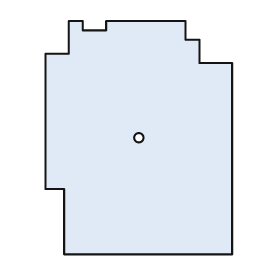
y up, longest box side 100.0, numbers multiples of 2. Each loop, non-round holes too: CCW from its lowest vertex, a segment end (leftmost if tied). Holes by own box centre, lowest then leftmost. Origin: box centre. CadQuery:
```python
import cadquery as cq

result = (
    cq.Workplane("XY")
    .moveTo(-32.0, -50.0)
    .lineTo(40.0, -50.0)
    .lineTo(40.0, 32.0)
    .lineTo(26.0, 32.0)
    .lineTo(26.0, 42.0)
    .lineTo(20.0, 42.0)
    .lineTo(20.0, 50.0)
    .lineTo(-14.0, 50.0)
    .lineTo(-14.0, 46.0)
    .lineTo(-24.0, 46.0)
    .lineTo(-24.0, 50.0)
    .lineTo(-30.0, 50.0)
    .lineTo(-30.0, 36.0)
    .lineTo(-40.0, 36.0)
    .lineTo(-40.0, -22.0)
    .lineTo(-32.0, -22.0)
    .close()
    .moveTo(0.0, 0.0)
    .circle(2.0)
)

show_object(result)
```